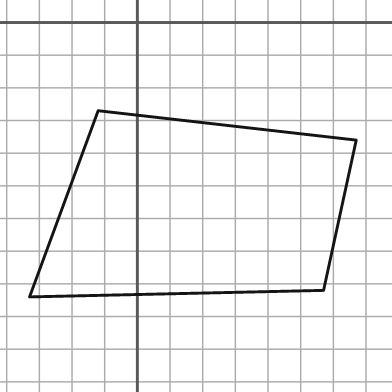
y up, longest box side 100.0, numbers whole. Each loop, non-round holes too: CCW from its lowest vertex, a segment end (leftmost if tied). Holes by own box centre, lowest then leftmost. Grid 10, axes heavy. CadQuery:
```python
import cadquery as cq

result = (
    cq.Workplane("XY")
    .moveTo(-33.0, -84.0)
    .lineTo(57.0, -82.0)
    .lineTo(67.0, -36.0)
    .lineTo(-12.0, -27.0)
    .close()
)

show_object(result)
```